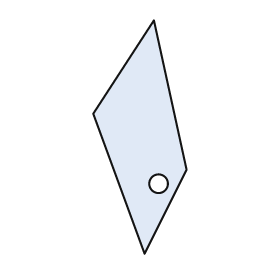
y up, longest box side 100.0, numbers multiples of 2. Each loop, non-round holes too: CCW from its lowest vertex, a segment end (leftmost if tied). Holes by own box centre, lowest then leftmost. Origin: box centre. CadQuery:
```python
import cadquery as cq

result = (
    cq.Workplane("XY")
    .moveTo(2.0, -50.0)
    .lineTo(20.0, -14.0)
    .lineTo(6.0, 50.0)
    .lineTo(-20.0, 10.0)
    .close()
    .moveTo(8.0, -20.0)
    .circle(4.0)
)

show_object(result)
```